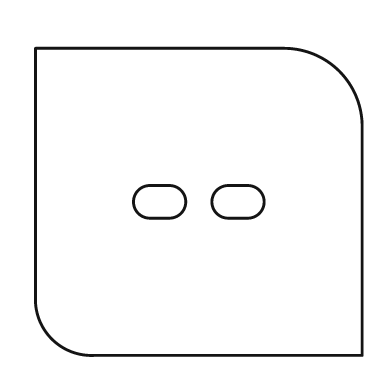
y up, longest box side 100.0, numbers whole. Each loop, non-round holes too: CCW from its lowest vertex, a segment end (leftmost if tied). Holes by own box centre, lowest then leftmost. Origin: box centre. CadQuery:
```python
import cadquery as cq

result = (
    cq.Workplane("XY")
    .moveTo(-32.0, -47.0)
    .lineTo(50.0, -47.0)
    .lineTo(50.0, 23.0)
    .threePointArc((43.0, 40.0), (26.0, 47.0))
    .lineTo(-50.0, 47.0)
    .lineTo(-50.0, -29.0)
    .threePointArc((-45.0, -42.0), (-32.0, -47.0))
    .close()
    .moveTo(-15.0, -5.0)
    .lineTo(-9.0, -5.0)
    .threePointArc((-4.0, 0.0), (-9.0, 5.0))
    .lineTo(-15.0, 5.0)
    .threePointArc((-20.0, 0.0), (-15.0, -5.0))
    .close()
    .moveTo(9.0, -5.0)
    .lineTo(15.0, -5.0)
    .threePointArc((20.0, 0.0), (15.0, 5.0))
    .lineTo(9.0, 5.0)
    .threePointArc((4.0, 0.0), (9.0, -5.0))
    .close()
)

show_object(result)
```